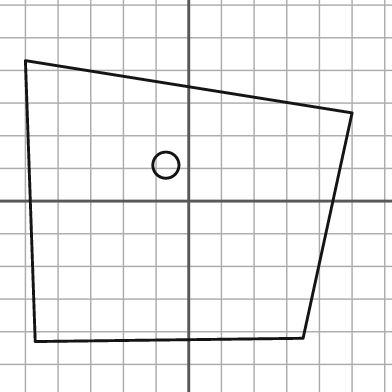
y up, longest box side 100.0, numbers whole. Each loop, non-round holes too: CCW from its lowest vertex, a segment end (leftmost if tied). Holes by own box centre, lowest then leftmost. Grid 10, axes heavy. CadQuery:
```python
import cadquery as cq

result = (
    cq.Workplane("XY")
    .moveTo(-47.0, -43.0)
    .lineTo(35.0, -42.0)
    .lineTo(50.0, 27.0)
    .lineTo(-50.0, 43.0)
    .close()
    .moveTo(-7.0, 11.0)
    .circle(4.0)
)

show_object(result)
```